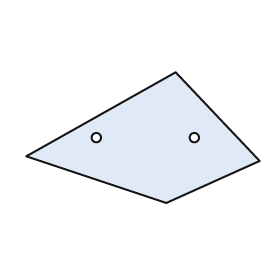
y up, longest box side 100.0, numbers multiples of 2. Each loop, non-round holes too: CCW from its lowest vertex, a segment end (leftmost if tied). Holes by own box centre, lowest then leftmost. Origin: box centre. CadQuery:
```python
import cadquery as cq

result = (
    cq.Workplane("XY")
    .moveTo(10.0, -28.0)
    .lineTo(50.0, -10.0)
    .lineTo(14.0, 28.0)
    .lineTo(-50.0, -8.0)
    .close()
    .moveTo(-20.0, 0.0)
    .circle(2.0)
    .moveTo(22.0, 0.0)
    .circle(2.0)
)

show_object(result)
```